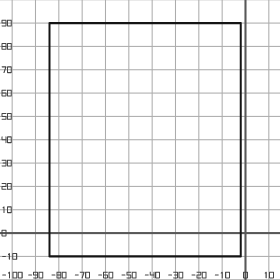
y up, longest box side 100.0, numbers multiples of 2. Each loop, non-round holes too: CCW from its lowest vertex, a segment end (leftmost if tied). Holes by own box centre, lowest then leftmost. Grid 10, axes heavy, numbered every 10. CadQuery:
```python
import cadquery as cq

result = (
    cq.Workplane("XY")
    .moveTo(-84.0, -10.0)
    .lineTo(-2.0, -10.0)
    .lineTo(-2.0, 90.0)
    .lineTo(-84.0, 90.0)
    .close()
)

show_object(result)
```